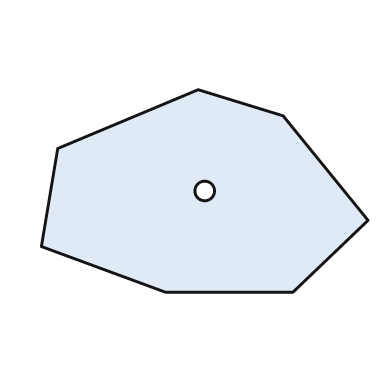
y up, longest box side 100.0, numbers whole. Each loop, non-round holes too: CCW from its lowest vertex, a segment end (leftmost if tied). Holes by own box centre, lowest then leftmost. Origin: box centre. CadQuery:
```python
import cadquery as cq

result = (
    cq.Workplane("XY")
    .moveTo(-12.0, -31.0)
    .lineTo(27.0, -31.0)
    .lineTo(50.0, -9.0)
    .lineTo(24.0, 23.0)
    .lineTo(-2.0, 31.0)
    .lineTo(-45.0, 13.0)
    .lineTo(-50.0, -17.0)
    .close()
    .moveTo(0.0, 0.0)
    .circle(3.0)
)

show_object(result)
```